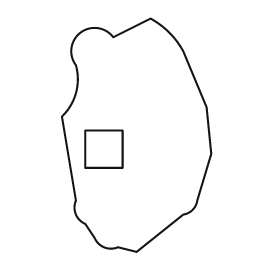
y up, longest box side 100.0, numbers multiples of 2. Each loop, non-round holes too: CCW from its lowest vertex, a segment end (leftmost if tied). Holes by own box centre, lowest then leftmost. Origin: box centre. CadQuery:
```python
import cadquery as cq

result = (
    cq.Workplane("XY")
    .moveTo(0.0, -50.0)
    .lineTo(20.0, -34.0)
    .threePointArc((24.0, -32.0), (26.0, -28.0))
    .lineTo(32.0, -8.0)
    .lineTo(30.0, 12.0)
    .lineTo(20.0, 36.0)
    .threePointArc((14.0, 44.0), (6.0, 50.0))
    .lineTo(-10.0, 42.0)
    .threePointArc((-24.0, 44.0), (-26.0, 30.0))
    .threePointArc((-26.0, 18.0), (-32.0, 8.0))
    .lineTo(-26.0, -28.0)
    .threePointArc((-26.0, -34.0), (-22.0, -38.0))
    .lineTo(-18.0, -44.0)
    .threePointArc((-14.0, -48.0), (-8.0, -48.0))
    .close()
    .moveTo(-22.0, -14.0)
    .lineTo(-6.0, -14.0)
    .lineTo(-6.0, 2.0)
    .lineTo(-22.0, 2.0)
    .close()
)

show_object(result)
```